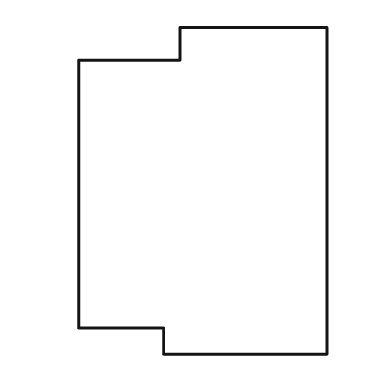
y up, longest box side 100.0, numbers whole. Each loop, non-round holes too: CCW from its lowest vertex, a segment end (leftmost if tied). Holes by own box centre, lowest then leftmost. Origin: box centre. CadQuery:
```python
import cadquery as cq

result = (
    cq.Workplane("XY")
    .moveTo(-12.0, -50.0)
    .lineTo(38.0, -50.0)
    .lineTo(38.0, 50.0)
    .lineTo(-7.0, 50.0)
    .lineTo(-7.0, 40.0)
    .lineTo(-38.0, 40.0)
    .lineTo(-38.0, -42.0)
    .lineTo(-12.0, -42.0)
    .close()
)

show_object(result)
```